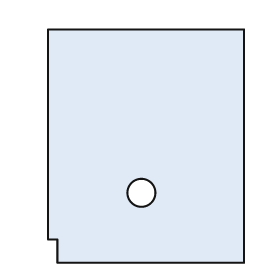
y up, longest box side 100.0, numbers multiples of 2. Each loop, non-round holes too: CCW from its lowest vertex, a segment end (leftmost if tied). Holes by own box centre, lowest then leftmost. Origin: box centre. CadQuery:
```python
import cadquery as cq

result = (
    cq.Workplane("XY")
    .moveTo(-38.0, -50.0)
    .lineTo(42.0, -50.0)
    .lineTo(42.0, 50.0)
    .lineTo(-42.0, 50.0)
    .lineTo(-42.0, -40.0)
    .lineTo(-38.0, -40.0)
    .close()
    .moveTo(-2.0, -20.0)
    .circle(6.0)
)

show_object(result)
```